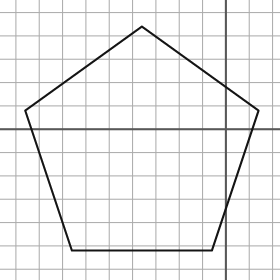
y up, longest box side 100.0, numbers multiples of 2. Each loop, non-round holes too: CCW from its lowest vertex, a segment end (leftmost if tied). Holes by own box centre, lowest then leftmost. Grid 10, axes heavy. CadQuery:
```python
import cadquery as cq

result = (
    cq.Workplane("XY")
    .moveTo(-66.0, -52.0)
    .lineTo(-6.0, -52.0)
    .lineTo(14.0, 8.0)
    .lineTo(-36.0, 44.0)
    .lineTo(-86.0, 8.0)
    .close()
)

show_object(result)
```